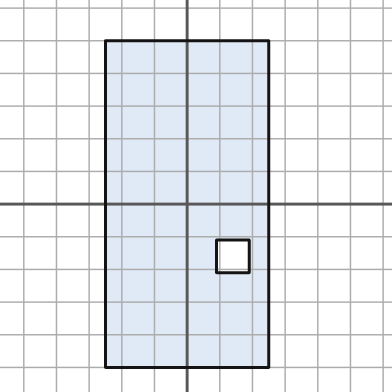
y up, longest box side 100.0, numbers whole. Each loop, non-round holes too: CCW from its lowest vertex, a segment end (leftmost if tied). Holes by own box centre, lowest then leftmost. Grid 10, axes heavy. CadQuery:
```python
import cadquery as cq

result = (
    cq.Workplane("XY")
    .moveTo(-25.0, -50.0)
    .lineTo(25.0, -50.0)
    .lineTo(25.0, 50.0)
    .lineTo(-25.0, 50.0)
    .close()
    .moveTo(9.0, -21.0)
    .lineTo(19.0, -21.0)
    .lineTo(19.0, -11.0)
    .lineTo(9.0, -11.0)
    .close()
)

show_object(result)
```